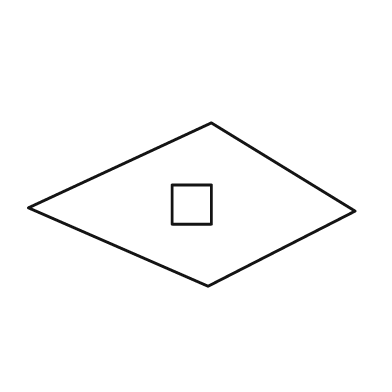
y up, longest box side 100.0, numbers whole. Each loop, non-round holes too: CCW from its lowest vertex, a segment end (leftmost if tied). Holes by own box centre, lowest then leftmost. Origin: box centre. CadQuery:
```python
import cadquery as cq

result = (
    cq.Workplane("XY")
    .moveTo(5.0, -25.0)
    .lineTo(50.0, -2.0)
    .lineTo(6.0, 25.0)
    .lineTo(-50.0, -1.0)
    .close()
    .moveTo(-6.0, -6.0)
    .lineTo(6.0, -6.0)
    .lineTo(6.0, 6.0)
    .lineTo(-6.0, 6.0)
    .close()
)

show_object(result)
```